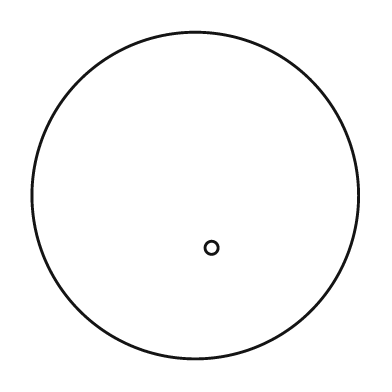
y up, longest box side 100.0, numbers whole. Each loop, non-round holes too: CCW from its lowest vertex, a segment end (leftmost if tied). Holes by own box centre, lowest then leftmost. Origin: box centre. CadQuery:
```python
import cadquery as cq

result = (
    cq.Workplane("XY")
    .moveTo(0.0, 0.0)
    .circle(50.0)
    .moveTo(5.0, -16.0)
    .circle(2.0)
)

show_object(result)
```